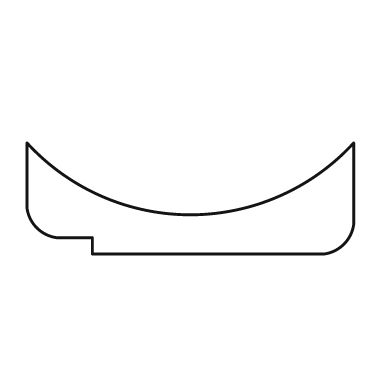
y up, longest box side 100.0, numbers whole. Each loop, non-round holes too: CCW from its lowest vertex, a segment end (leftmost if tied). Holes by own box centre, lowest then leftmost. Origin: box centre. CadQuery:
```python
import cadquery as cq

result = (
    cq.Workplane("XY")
    .moveTo(-30.0, -17.0)
    .lineTo(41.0, -17.0)
    .threePointArc((47.0, -14.0), (50.0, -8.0))
    .lineTo(50.0, 17.0)
    .threePointArc((0.0, -5.0), (-50.0, 17.0))
    .lineTo(-50.0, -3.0)
    .threePointArc((-47.0, -9.0), (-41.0, -12.0))
    .lineTo(-30.0, -12.0)
    .close()
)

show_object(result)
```